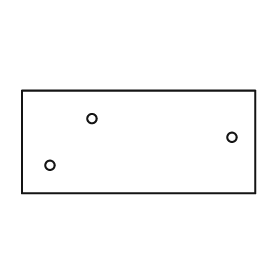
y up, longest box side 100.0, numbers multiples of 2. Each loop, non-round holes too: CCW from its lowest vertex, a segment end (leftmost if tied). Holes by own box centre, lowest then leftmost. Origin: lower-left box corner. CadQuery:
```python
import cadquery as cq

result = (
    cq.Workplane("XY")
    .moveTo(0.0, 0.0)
    .lineTo(100.0, 0.0)
    .lineTo(100.0, 44.0)
    .lineTo(0.0, 44.0)
    .close()
    .moveTo(12.0, 12.0)
    .circle(2.0)
    .moveTo(90.0, 24.0)
    .circle(2.0)
    .moveTo(30.0, 32.0)
    .circle(2.0)
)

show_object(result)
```